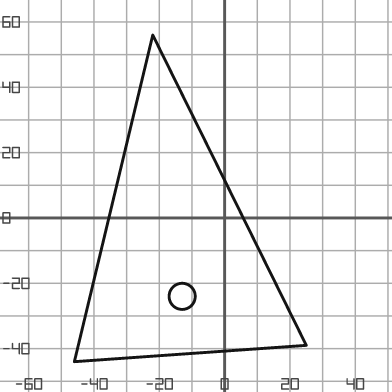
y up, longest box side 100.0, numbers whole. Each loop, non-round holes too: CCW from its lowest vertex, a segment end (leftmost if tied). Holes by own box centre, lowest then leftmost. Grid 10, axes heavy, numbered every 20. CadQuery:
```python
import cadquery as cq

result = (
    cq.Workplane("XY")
    .moveTo(-46.0, -44.0)
    .lineTo(25.0, -39.0)
    .lineTo(-22.0, 56.0)
    .close()
    .moveTo(-13.0, -24.0)
    .circle(4.0)
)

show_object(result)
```